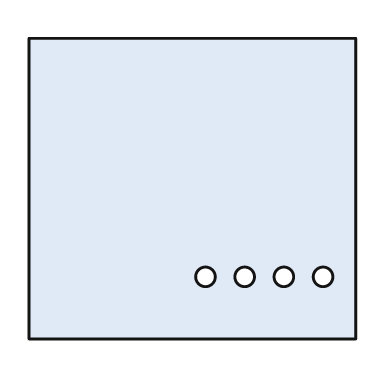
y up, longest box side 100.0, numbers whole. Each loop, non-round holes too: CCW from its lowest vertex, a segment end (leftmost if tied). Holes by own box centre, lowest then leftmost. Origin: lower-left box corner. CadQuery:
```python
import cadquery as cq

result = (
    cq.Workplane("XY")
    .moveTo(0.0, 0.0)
    .lineTo(100.0, 0.0)
    .lineTo(100.0, 92.0)
    .lineTo(0.0, 92.0)
    .close()
    .moveTo(54.0, 19.0)
    .circle(3.0)
    .moveTo(66.0, 19.0)
    .circle(3.0)
    .moveTo(78.0, 19.0)
    .circle(3.0)
    .moveTo(90.0, 19.0)
    .circle(3.0)
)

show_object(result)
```